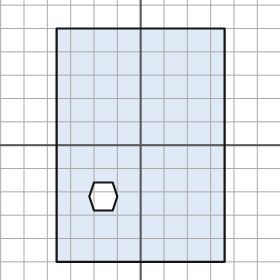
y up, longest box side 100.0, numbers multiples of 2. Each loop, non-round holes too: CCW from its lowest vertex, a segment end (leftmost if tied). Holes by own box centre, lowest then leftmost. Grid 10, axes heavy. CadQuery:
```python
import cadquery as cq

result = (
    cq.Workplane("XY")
    .moveTo(-36.0, -50.0)
    .lineTo(36.0, -50.0)
    .lineTo(36.0, 50.0)
    .lineTo(-36.0, 50.0)
    .close()
    .moveTo(-20.0, -28.0)
    .lineTo(-12.0, -28.0)
    .lineTo(-10.0, -22.0)
    .lineTo(-12.0, -16.0)
    .lineTo(-20.0, -16.0)
    .lineTo(-22.0, -22.0)
    .close()
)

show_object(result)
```